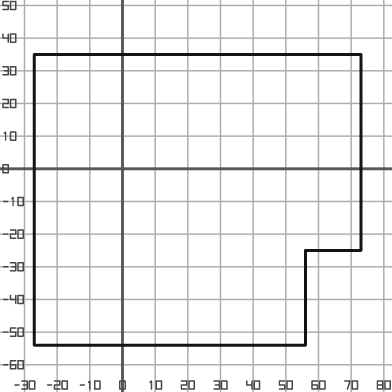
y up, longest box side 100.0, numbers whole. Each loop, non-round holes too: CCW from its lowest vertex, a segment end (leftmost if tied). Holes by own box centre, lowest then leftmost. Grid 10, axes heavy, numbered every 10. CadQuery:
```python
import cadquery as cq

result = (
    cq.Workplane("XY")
    .moveTo(-27.0, -54.0)
    .lineTo(56.0, -54.0)
    .lineTo(56.0, -25.0)
    .lineTo(73.0, -25.0)
    .lineTo(73.0, 35.0)
    .lineTo(-27.0, 35.0)
    .close()
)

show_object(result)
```